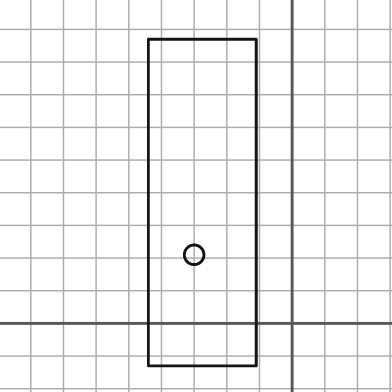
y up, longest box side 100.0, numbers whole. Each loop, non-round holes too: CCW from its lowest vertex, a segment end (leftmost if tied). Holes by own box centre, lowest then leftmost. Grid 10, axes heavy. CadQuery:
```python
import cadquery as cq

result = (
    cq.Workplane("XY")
    .moveTo(-44.0, -13.0)
    .lineTo(-11.0, -13.0)
    .lineTo(-11.0, 87.0)
    .lineTo(-44.0, 87.0)
    .close()
    .moveTo(-30.0, 21.0)
    .circle(3.0)
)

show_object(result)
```